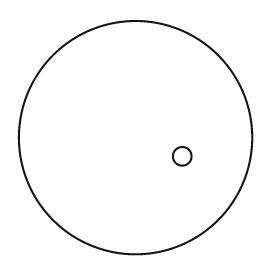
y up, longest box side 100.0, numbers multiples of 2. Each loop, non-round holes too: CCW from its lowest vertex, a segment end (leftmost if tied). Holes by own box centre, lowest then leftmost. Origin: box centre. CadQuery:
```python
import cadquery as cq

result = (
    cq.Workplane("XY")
    .moveTo(0.0, 0.0)
    .circle(50.0)
    .moveTo(20.0, -8.0)
    .circle(4.0)
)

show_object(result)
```